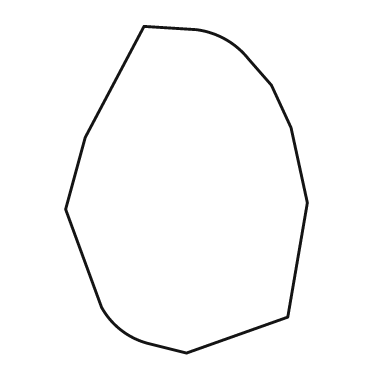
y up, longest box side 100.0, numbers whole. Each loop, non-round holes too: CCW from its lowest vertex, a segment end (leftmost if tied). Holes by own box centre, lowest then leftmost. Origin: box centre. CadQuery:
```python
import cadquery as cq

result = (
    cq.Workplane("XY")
    .moveTo(0.0, -50.0)
    .lineTo(31.0, -39.0)
    .lineTo(37.0, -4.0)
    .lineTo(32.0, 19.0)
    .lineTo(26.0, 32.0)
    .lineTo(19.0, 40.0)
    .threePointArc((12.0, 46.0), (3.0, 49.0))
    .lineTo(-13.0, 50.0)
    .lineTo(-31.0, 16.0)
    .lineTo(-37.0, -6.0)
    .lineTo(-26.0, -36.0)
    .threePointArc((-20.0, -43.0), (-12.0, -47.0))
    .close()
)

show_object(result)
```